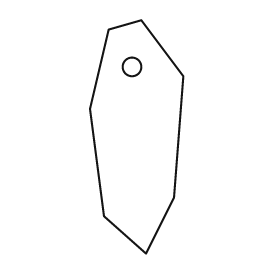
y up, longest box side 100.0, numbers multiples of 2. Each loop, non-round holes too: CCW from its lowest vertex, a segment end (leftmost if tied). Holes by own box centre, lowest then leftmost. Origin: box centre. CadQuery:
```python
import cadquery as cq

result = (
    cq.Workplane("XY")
    .moveTo(4.0, -50.0)
    .lineTo(16.0, -26.0)
    .lineTo(20.0, 26.0)
    .lineTo(2.0, 50.0)
    .lineTo(-12.0, 46.0)
    .lineTo(-20.0, 12.0)
    .lineTo(-14.0, -34.0)
    .close()
    .moveTo(-2.0, 30.0)
    .circle(4.0)
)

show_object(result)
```